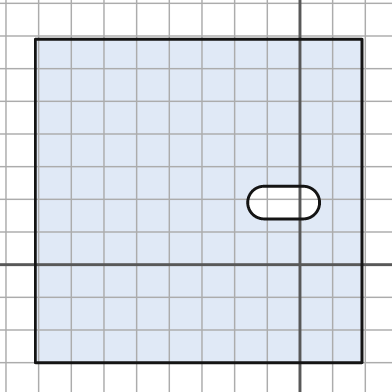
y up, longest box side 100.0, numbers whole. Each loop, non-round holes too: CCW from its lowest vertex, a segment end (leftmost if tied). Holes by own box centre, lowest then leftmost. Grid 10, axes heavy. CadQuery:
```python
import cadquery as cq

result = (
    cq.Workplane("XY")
    .moveTo(-81.0, -30.0)
    .lineTo(19.0, -30.0)
    .lineTo(19.0, 69.0)
    .lineTo(-81.0, 69.0)
    .close()
    .moveTo(-11.0, 14.0)
    .lineTo(1.0, 14.0)
    .threePointArc((6.0, 19.0), (1.0, 24.0))
    .lineTo(-11.0, 24.0)
    .threePointArc((-16.0, 19.0), (-11.0, 14.0))
    .close()
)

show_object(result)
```